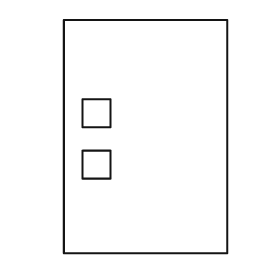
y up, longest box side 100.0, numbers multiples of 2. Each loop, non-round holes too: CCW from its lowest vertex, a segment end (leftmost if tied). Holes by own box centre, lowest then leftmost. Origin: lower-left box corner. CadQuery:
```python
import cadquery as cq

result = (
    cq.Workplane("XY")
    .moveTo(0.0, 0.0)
    .lineTo(70.0, 0.0)
    .lineTo(70.0, 100.0)
    .lineTo(0.0, 100.0)
    .close()
    .moveTo(8.0, 32.0)
    .lineTo(20.0, 32.0)
    .lineTo(20.0, 44.0)
    .lineTo(8.0, 44.0)
    .close()
    .moveTo(8.0, 54.0)
    .lineTo(20.0, 54.0)
    .lineTo(20.0, 66.0)
    .lineTo(8.0, 66.0)
    .close()
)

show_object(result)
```